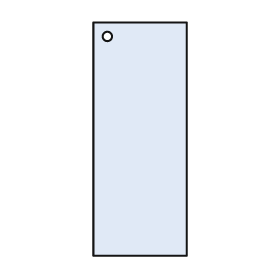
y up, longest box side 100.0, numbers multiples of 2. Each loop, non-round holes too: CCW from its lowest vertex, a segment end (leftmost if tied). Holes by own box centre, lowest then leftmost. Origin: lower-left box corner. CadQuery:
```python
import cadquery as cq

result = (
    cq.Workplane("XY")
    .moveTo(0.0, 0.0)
    .lineTo(40.0, 0.0)
    .lineTo(40.0, 100.0)
    .lineTo(0.0, 100.0)
    .close()
    .moveTo(6.0, 94.0)
    .circle(2.0)
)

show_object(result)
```